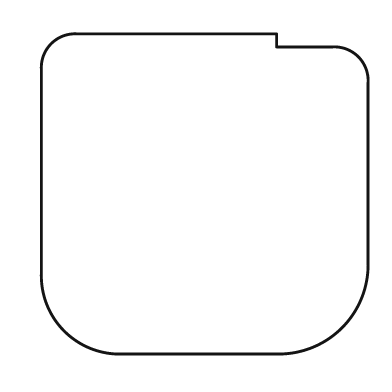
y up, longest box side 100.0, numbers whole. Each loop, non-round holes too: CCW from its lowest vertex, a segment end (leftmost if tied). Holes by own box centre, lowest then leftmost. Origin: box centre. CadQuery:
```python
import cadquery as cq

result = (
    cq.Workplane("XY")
    .moveTo(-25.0, -49.0)
    .lineTo(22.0, -49.0)
    .threePointArc((42.0, -41.0), (50.0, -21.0))
    .lineTo(50.0, 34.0)
    .threePointArc((47.0, 42.0), (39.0, 45.0))
    .lineTo(22.0, 45.0)
    .lineTo(22.0, 49.0)
    .lineTo(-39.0, 49.0)
    .threePointArc((-47.0, 46.0), (-50.0, 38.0))
    .lineTo(-50.0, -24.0)
    .threePointArc((-43.0, -42.0), (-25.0, -49.0))
    .close()
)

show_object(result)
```